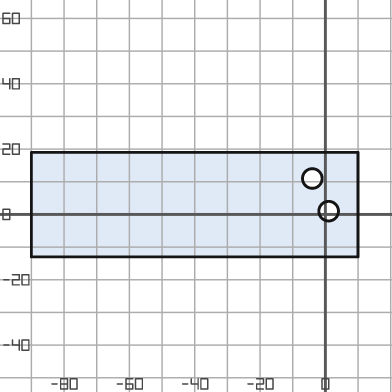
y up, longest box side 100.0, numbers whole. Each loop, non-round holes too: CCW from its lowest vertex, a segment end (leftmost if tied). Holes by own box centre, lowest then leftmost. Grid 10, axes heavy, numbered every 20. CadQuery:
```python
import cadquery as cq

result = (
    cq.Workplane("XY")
    .moveTo(-90.0, -13.0)
    .lineTo(10.0, -13.0)
    .lineTo(10.0, 19.0)
    .lineTo(-90.0, 19.0)
    .close()
    .moveTo(1.0, 1.0)
    .circle(3.0)
    .moveTo(-4.0, 11.0)
    .circle(3.0)
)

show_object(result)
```